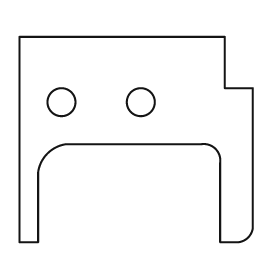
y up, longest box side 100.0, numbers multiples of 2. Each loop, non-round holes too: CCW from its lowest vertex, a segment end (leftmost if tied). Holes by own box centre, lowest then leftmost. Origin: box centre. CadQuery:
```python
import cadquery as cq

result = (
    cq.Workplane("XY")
    .moveTo(-50.0, -44.0)
    .lineTo(-42.0, -44.0)
    .lineTo(-42.0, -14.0)
    .threePointArc((-38.0, -6.0), (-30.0, -2.0))
    .lineTo(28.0, -2.0)
    .threePointArc((34.0, -4.0), (36.0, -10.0))
    .lineTo(36.0, -44.0)
    .lineTo(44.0, -44.0)
    .threePointArc((48.0, -42.0), (50.0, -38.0))
    .lineTo(50.0, 22.0)
    .lineTo(38.0, 22.0)
    .lineTo(38.0, 44.0)
    .lineTo(-50.0, 44.0)
    .close()
    .moveTo(-32.0, 16.0)
    .circle(6.0)
    .moveTo(2.0, 16.0)
    .circle(6.0)
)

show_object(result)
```